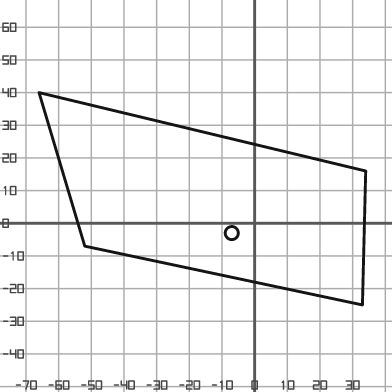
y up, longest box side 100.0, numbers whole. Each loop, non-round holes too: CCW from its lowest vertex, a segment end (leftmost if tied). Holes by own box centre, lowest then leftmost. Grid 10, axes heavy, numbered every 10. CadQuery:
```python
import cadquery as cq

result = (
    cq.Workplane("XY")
    .moveTo(33.0, -25.0)
    .lineTo(34.0, 16.0)
    .lineTo(-66.0, 40.0)
    .lineTo(-52.0, -7.0)
    .close()
    .moveTo(-7.0, -3.0)
    .circle(2.0)
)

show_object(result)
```